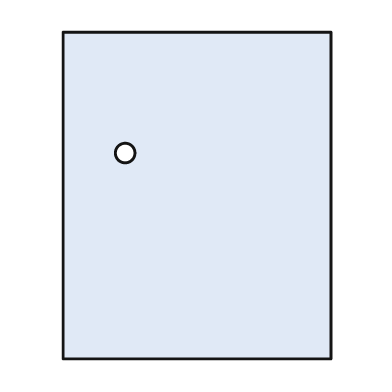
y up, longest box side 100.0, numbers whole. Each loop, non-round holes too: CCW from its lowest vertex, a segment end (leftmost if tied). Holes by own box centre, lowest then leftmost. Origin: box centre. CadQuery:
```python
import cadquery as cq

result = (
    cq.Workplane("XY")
    .moveTo(-41.0, -50.0)
    .lineTo(41.0, -50.0)
    .lineTo(41.0, 50.0)
    .lineTo(-41.0, 50.0)
    .close()
    .moveTo(-22.0, 13.0)
    .circle(3.0)
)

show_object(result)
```